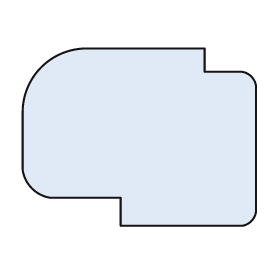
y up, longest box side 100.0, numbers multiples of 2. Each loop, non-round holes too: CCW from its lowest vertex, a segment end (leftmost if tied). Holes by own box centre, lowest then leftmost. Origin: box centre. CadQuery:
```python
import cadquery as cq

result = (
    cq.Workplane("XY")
    .moveTo(-8.0, -38.0)
    .lineTo(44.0, -38.0)
    .threePointArc((48.0, -36.0), (50.0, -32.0))
    .lineTo(50.0, 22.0)
    .threePointArc((48.0, 26.0), (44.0, 28.0))
    .lineTo(28.0, 28.0)
    .lineTo(28.0, 38.0)
    .lineTo(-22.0, 38.0)
    .threePointArc((-42.0, 30.0), (-50.0, 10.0))
    .lineTo(-50.0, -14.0)
    .threePointArc((-46.0, -22.0), (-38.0, -26.0))
    .lineTo(-8.0, -26.0)
    .close()
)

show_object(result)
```